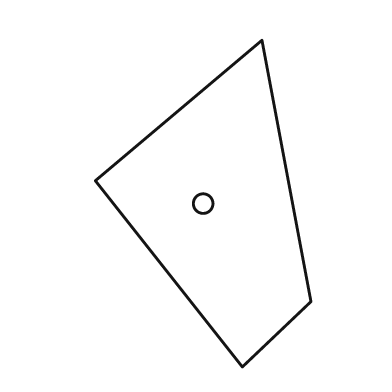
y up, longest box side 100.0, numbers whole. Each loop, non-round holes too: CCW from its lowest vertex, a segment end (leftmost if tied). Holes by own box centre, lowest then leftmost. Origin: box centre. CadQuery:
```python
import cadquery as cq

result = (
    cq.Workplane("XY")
    .moveTo(12.0, -50.0)
    .lineTo(33.0, -30.0)
    .lineTo(18.0, 50.0)
    .lineTo(-33.0, 7.0)
    .close()
    .moveTo(0.0, 0.0)
    .circle(3.0)
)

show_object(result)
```